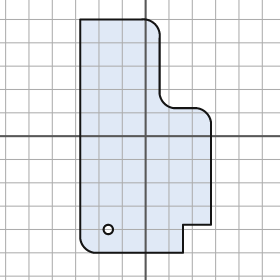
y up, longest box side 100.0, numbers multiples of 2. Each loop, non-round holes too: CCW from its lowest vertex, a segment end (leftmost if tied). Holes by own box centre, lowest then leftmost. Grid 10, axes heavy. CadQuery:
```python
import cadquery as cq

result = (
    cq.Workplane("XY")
    .moveTo(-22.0, -50.0)
    .lineTo(16.0, -50.0)
    .lineTo(16.0, -38.0)
    .lineTo(28.0, -38.0)
    .lineTo(28.0, 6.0)
    .threePointArc((26.0, 10.0), (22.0, 12.0))
    .lineTo(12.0, 12.0)
    .threePointArc((8.0, 14.0), (6.0, 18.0))
    .lineTo(6.0, 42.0)
    .threePointArc((4.0, 48.0), (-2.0, 50.0))
    .lineTo(-28.0, 50.0)
    .lineTo(-28.0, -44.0)
    .threePointArc((-26.0, -48.0), (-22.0, -50.0))
    .close()
    .moveTo(-16.0, -40.0)
    .circle(2.0)
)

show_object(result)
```